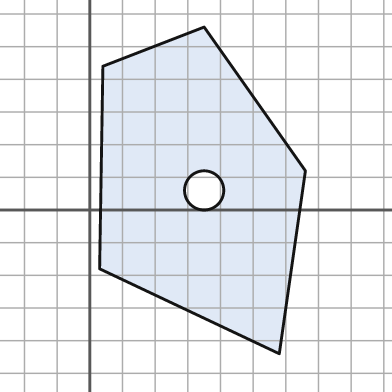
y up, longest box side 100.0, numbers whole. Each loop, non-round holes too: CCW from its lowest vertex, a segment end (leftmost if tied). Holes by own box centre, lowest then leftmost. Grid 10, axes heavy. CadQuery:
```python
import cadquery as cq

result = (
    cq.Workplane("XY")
    .moveTo(58.0, -44.0)
    .lineTo(66.0, 12.0)
    .lineTo(35.0, 56.0)
    .lineTo(4.0, 44.0)
    .lineTo(3.0, -18.0)
    .close()
    .moveTo(35.0, 6.0)
    .circle(6.0)
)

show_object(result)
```